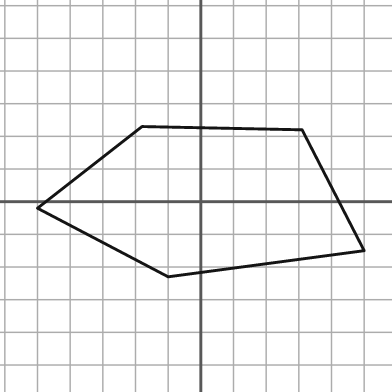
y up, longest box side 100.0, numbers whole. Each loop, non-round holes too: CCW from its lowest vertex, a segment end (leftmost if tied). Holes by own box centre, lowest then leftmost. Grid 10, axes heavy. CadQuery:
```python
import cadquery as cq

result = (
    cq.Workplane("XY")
    .moveTo(-10.0, -23.0)
    .lineTo(50.0, -15.0)
    .lineTo(31.0, 22.0)
    .lineTo(-18.0, 23.0)
    .lineTo(-50.0, -2.0)
    .close()
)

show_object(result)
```